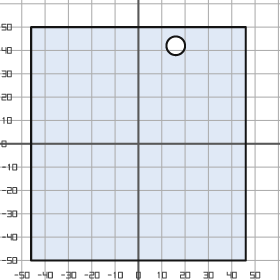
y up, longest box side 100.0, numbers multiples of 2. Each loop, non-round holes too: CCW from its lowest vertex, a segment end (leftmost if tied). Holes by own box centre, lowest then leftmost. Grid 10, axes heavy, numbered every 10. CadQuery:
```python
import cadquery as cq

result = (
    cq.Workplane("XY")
    .moveTo(-46.0, -50.0)
    .lineTo(46.0, -50.0)
    .lineTo(46.0, 50.0)
    .lineTo(-46.0, 50.0)
    .close()
    .moveTo(16.0, 42.0)
    .circle(4.0)
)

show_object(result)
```